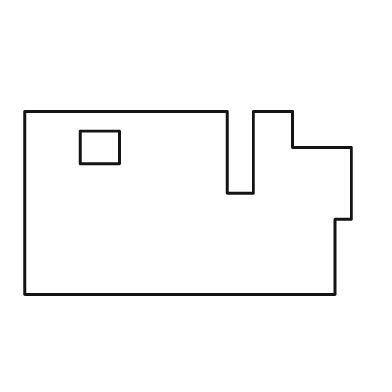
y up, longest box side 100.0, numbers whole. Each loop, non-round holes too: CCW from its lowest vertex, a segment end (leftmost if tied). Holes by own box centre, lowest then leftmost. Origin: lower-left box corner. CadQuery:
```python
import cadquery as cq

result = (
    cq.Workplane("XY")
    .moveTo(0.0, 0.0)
    .lineTo(95.0, 0.0)
    .lineTo(95.0, 23.0)
    .lineTo(100.0, 23.0)
    .lineTo(100.0, 45.0)
    .lineTo(82.0, 45.0)
    .lineTo(82.0, 56.0)
    .lineTo(70.0, 56.0)
    .lineTo(70.0, 31.0)
    .lineTo(62.0, 31.0)
    .lineTo(62.0, 56.0)
    .lineTo(0.0, 56.0)
    .close()
    .moveTo(17.0, 40.0)
    .lineTo(29.0, 40.0)
    .lineTo(29.0, 50.0)
    .lineTo(17.0, 50.0)
    .close()
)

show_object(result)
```